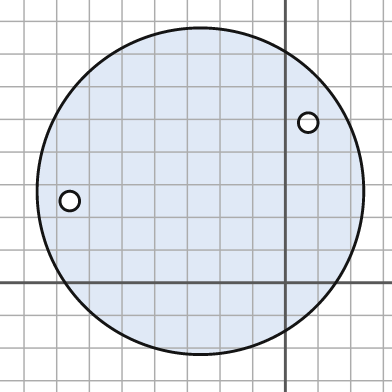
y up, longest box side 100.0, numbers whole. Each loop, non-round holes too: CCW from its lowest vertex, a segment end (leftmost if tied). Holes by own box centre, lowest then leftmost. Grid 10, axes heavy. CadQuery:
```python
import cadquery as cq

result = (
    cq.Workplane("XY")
    .moveTo(-26.0, 28.0)
    .circle(50.0)
    .moveTo(-66.0, 25.0)
    .circle(3.0)
    .moveTo(7.0, 49.0)
    .circle(3.0)
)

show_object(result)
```